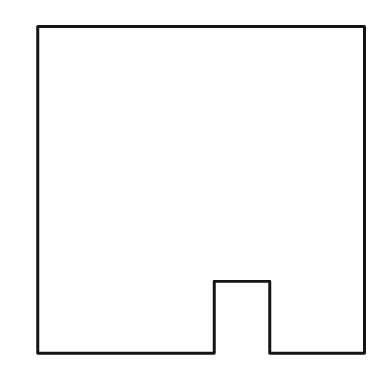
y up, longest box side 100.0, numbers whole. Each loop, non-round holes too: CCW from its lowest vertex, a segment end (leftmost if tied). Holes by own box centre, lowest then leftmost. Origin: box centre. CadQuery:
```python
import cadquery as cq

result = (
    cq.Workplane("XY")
    .moveTo(-50.0, -50.0)
    .lineTo(4.0, -50.0)
    .lineTo(4.0, -28.0)
    .lineTo(21.0, -28.0)
    .lineTo(21.0, -50.0)
    .lineTo(50.0, -50.0)
    .lineTo(50.0, 50.0)
    .lineTo(-50.0, 50.0)
    .close()
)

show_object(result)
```